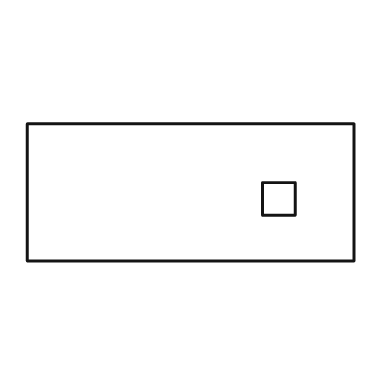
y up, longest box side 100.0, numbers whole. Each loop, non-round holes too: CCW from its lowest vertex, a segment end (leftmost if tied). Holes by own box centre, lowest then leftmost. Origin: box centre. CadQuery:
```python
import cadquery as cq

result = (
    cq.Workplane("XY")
    .moveTo(-50.0, -21.0)
    .lineTo(50.0, -21.0)
    .lineTo(50.0, 21.0)
    .lineTo(-50.0, 21.0)
    .close()
    .moveTo(22.0, -7.0)
    .lineTo(32.0, -7.0)
    .lineTo(32.0, 3.0)
    .lineTo(22.0, 3.0)
    .close()
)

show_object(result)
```